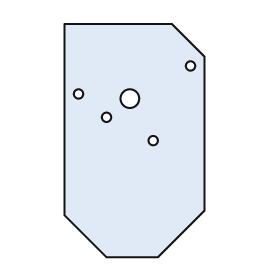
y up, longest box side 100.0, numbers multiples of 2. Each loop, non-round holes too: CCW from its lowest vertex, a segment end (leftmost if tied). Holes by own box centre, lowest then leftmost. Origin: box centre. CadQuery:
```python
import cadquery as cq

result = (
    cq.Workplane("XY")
    .moveTo(-12.0, -50.0)
    .lineTo(10.0, -50.0)
    .lineTo(30.0, -30.0)
    .lineTo(30.0, 36.0)
    .lineTo(16.0, 50.0)
    .lineTo(-30.0, 50.0)
    .lineTo(-30.0, -32.0)
    .close()
    .moveTo(8.0, 0.0)
    .circle(2.0)
    .moveTo(-12.0, 10.0)
    .circle(2.0)
    .moveTo(-2.0, 18.0)
    .circle(4.0)
    .moveTo(-24.0, 20.0)
    .circle(2.0)
    .moveTo(24.0, 32.0)
    .circle(2.0)
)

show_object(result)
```